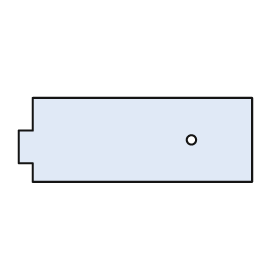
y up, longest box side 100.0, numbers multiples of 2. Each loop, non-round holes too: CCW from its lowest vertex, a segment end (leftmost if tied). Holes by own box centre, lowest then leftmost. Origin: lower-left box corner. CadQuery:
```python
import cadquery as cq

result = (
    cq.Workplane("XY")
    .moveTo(6.0, 0.0)
    .lineTo(100.0, 0.0)
    .lineTo(100.0, 36.0)
    .lineTo(6.0, 36.0)
    .lineTo(6.0, 22.0)
    .lineTo(0.0, 22.0)
    .lineTo(0.0, 8.0)
    .lineTo(6.0, 8.0)
    .close()
    .moveTo(74.0, 18.0)
    .circle(2.0)
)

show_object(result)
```